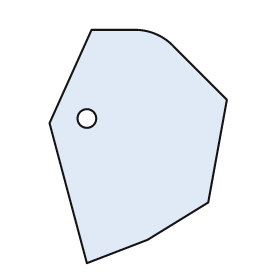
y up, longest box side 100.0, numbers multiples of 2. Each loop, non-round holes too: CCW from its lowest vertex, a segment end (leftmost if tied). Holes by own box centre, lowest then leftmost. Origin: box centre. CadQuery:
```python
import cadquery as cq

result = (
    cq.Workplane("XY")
    .moveTo(-22.0, -50.0)
    .lineTo(4.0, -40.0)
    .lineTo(30.0, -24.0)
    .lineTo(38.0, 20.0)
    .lineTo(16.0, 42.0)
    .threePointArc((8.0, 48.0), (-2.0, 50.0))
    .lineTo(-20.0, 50.0)
    .lineTo(-38.0, 10.0)
    .close()
    .moveTo(-22.0, 12.0)
    .circle(4.0)
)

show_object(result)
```